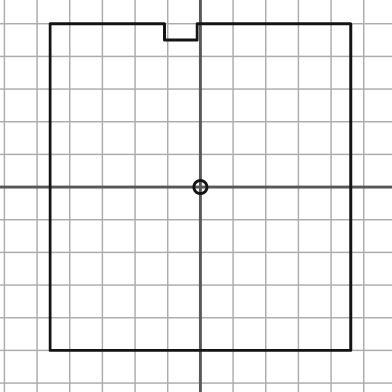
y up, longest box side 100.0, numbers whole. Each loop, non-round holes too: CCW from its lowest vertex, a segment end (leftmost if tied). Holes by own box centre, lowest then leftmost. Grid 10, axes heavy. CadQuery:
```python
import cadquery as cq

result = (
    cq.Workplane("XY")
    .moveTo(-46.0, -50.0)
    .lineTo(46.0, -50.0)
    .lineTo(46.0, 50.0)
    .lineTo(-1.0, 50.0)
    .lineTo(-1.0, 45.0)
    .lineTo(-11.0, 45.0)
    .lineTo(-11.0, 50.0)
    .lineTo(-46.0, 50.0)
    .close()
    .moveTo(0.0, 0.0)
    .circle(2.0)
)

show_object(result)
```